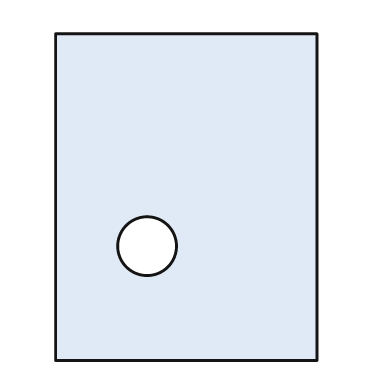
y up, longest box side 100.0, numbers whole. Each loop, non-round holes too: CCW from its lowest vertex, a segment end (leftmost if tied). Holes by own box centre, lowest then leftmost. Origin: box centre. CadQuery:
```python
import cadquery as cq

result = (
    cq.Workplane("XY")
    .moveTo(-40.0, -50.0)
    .lineTo(40.0, -50.0)
    .lineTo(40.0, 50.0)
    .lineTo(-40.0, 50.0)
    .close()
    .moveTo(-12.0, -15.0)
    .circle(9.0)
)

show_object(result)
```